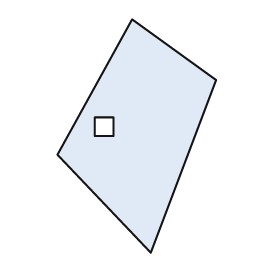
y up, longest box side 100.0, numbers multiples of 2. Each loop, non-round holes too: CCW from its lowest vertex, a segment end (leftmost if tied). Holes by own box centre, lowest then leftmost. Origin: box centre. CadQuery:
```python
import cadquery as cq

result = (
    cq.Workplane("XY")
    .moveTo(6.0, -50.0)
    .lineTo(34.0, 24.0)
    .lineTo(-2.0, 50.0)
    .lineTo(-34.0, -8.0)
    .close()
    .moveTo(-18.0, 0.0)
    .lineTo(-10.0, 0.0)
    .lineTo(-10.0, 8.0)
    .lineTo(-18.0, 8.0)
    .close()
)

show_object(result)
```